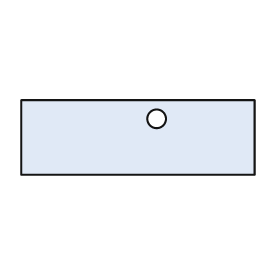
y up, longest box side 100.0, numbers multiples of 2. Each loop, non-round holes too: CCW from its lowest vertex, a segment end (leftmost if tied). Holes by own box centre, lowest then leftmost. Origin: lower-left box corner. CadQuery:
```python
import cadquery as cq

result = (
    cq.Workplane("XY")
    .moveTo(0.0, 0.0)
    .lineTo(100.0, 0.0)
    .lineTo(100.0, 32.0)
    .lineTo(0.0, 32.0)
    .close()
    .moveTo(58.0, 24.0)
    .circle(4.0)
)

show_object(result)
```